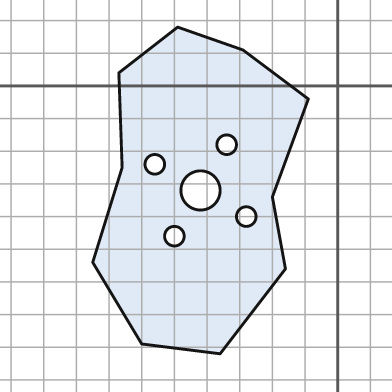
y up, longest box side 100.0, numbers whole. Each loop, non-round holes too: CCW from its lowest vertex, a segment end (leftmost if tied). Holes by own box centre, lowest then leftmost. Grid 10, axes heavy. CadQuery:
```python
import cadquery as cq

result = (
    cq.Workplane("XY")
    .moveTo(-36.0, -82.0)
    .lineTo(-16.0, -56.0)
    .lineTo(-20.0, -34.0)
    .lineTo(-9.0, -4.0)
    .lineTo(-29.0, 11.0)
    .lineTo(-49.0, 18.0)
    .lineTo(-67.0, 4.0)
    .lineTo(-66.0, -25.0)
    .lineTo(-75.0, -54.0)
    .lineTo(-60.0, -79.0)
    .close()
    .moveTo(-50.0, -46.0)
    .circle(3.0)
    .moveTo(-28.0, -40.0)
    .circle(3.0)
    .moveTo(-42.0, -32.0)
    .circle(6.0)
    .moveTo(-56.0, -24.0)
    .circle(3.0)
    .moveTo(-34.0, -18.0)
    .circle(3.0)
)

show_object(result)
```